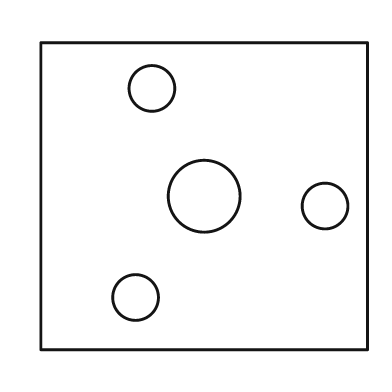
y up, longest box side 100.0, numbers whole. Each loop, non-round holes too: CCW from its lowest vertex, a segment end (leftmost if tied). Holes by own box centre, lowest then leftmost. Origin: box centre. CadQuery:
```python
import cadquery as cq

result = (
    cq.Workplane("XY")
    .moveTo(-50.0, -47.0)
    .lineTo(50.0, -47.0)
    .lineTo(50.0, 47.0)
    .lineTo(-50.0, 47.0)
    .close()
    .moveTo(-21.0, -31.0)
    .circle(7.0)
    .moveTo(37.0, -3.0)
    .circle(7.0)
    .moveTo(0.0, 0.0)
    .circle(11.0)
    .moveTo(-16.0, 33.0)
    .circle(7.0)
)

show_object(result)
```